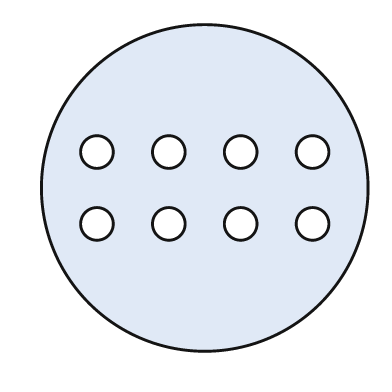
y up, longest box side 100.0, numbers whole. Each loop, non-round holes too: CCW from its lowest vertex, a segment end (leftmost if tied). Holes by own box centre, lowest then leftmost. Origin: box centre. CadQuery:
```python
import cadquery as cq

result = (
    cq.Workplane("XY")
    .moveTo(0.0, 0.0)
    .circle(50.0)
    .moveTo(-33.0, -11.0)
    .circle(5.0)
    .moveTo(-11.0, -11.0)
    .circle(5.0)
    .moveTo(11.0, -11.0)
    .circle(5.0)
    .moveTo(33.0, -11.0)
    .circle(5.0)
    .moveTo(-33.0, 11.0)
    .circle(5.0)
    .moveTo(-11.0, 11.0)
    .circle(5.0)
    .moveTo(11.0, 11.0)
    .circle(5.0)
    .moveTo(33.0, 11.0)
    .circle(5.0)
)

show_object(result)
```